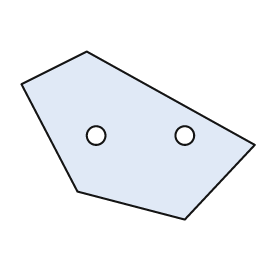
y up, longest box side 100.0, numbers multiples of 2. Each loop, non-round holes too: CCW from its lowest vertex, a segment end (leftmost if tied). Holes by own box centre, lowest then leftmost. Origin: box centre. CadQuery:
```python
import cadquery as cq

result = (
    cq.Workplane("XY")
    .moveTo(20.0, -36.0)
    .lineTo(50.0, -4.0)
    .lineTo(-22.0, 36.0)
    .lineTo(-50.0, 22.0)
    .lineTo(-26.0, -24.0)
    .close()
    .moveTo(-18.0, 0.0)
    .circle(4.0)
    .moveTo(20.0, 0.0)
    .circle(4.0)
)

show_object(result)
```